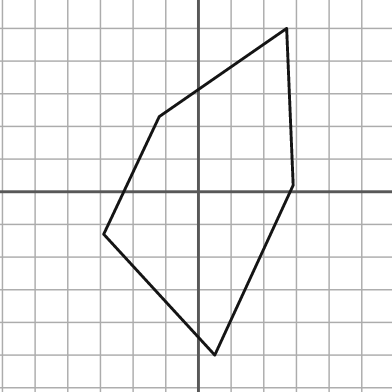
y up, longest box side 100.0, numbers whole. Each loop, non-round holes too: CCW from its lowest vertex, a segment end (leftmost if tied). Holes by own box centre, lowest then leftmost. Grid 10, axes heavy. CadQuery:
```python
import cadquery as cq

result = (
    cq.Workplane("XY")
    .moveTo(5.0, -50.0)
    .lineTo(29.0, 2.0)
    .lineTo(27.0, 50.0)
    .lineTo(-12.0, 23.0)
    .lineTo(-29.0, -13.0)
    .close()
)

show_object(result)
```